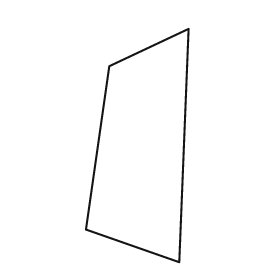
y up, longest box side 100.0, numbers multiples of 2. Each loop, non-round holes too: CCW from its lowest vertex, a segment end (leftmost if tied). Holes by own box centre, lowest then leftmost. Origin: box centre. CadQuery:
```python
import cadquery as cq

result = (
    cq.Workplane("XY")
    .moveTo(18.0, -50.0)
    .lineTo(22.0, 50.0)
    .lineTo(-12.0, 34.0)
    .lineTo(-22.0, -36.0)
    .close()
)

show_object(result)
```